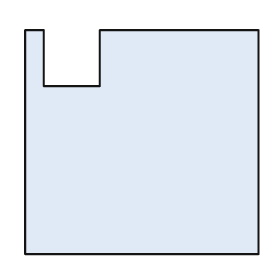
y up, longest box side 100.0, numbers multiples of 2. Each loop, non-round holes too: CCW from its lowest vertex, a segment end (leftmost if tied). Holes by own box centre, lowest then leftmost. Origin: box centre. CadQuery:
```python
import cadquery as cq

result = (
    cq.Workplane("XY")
    .moveTo(-50.0, -48.0)
    .lineTo(50.0, -48.0)
    .lineTo(50.0, 48.0)
    .lineTo(-18.0, 48.0)
    .lineTo(-18.0, 24.0)
    .lineTo(-42.0, 24.0)
    .lineTo(-42.0, 48.0)
    .lineTo(-50.0, 48.0)
    .close()
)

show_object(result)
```